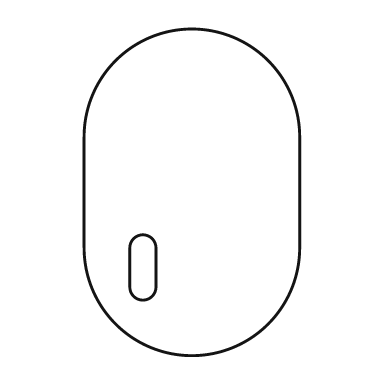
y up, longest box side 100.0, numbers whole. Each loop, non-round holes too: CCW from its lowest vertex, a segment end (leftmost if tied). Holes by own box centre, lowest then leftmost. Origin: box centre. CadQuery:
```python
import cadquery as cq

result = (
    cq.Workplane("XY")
    .moveTo(-33.0, -17.0)
    .threePointArc((0.0, -50.0), (33.0, -17.0))
    .lineTo(33.0, 17.0)
    .threePointArc((0.0, 50.0), (-33.0, 17.0))
    .close()
    .moveTo(-19.0, -29.0)
    .threePointArc((-15.0, -33.0), (-11.0, -29.0))
    .lineTo(-11.0, -17.0)
    .threePointArc((-15.0, -13.0), (-19.0, -17.0))
    .close()
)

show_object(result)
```